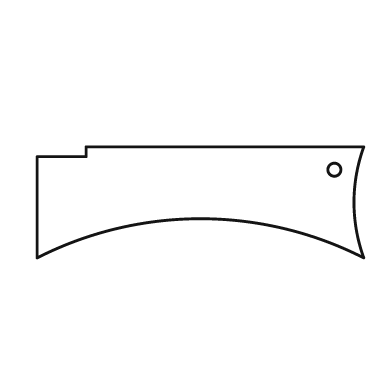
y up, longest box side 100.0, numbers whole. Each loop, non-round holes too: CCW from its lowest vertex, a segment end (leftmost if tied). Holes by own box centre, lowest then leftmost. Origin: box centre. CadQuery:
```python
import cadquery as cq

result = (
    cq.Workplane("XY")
    .moveTo(-50.0, -17.0)
    .threePointArc((0.0, -5.0), (50.0, -17.0))
    .threePointArc((47.0, 0.0), (50.0, 17.0))
    .lineTo(-35.0, 17.0)
    .lineTo(-35.0, 14.0)
    .lineTo(-50.0, 14.0)
    .close()
    .moveTo(41.0, 10.0)
    .circle(2.0)
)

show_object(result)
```